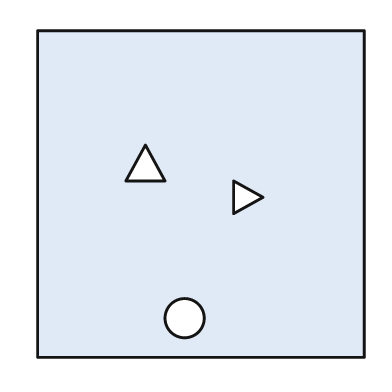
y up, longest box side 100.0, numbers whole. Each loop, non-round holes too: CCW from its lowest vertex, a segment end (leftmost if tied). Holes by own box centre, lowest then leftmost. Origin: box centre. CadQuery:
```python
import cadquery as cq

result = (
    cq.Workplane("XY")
    .moveTo(-50.0, -50.0)
    .lineTo(50.0, -50.0)
    .lineTo(50.0, 50.0)
    .lineTo(-50.0, 50.0)
    .close()
    .moveTo(-5.0, -38.0)
    .circle(6.0)
    .moveTo(10.0, -6.0)
    .lineTo(19.0, -1.0)
    .lineTo(10.0, 4.0)
    .close()
    .moveTo(-23.0, 4.0)
    .lineTo(-11.0, 4.0)
    .lineTo(-17.0, 15.0)
    .close()
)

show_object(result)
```